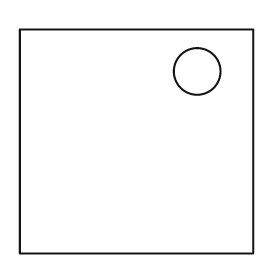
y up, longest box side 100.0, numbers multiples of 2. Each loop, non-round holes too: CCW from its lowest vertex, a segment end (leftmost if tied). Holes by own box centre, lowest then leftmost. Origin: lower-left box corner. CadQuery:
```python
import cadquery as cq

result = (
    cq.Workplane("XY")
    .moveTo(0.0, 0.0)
    .lineTo(100.0, 0.0)
    .lineTo(100.0, 96.0)
    .lineTo(0.0, 96.0)
    .close()
    .moveTo(76.0, 78.0)
    .circle(10.0)
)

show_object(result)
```